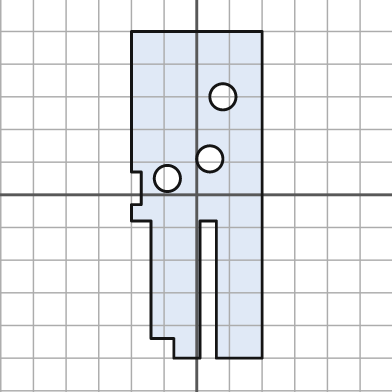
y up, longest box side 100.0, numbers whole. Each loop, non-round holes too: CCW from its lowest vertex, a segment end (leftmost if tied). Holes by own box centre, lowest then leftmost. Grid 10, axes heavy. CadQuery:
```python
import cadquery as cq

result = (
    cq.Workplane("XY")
    .moveTo(-7.0, -50.0)
    .lineTo(1.0, -50.0)
    .lineTo(1.0, -8.0)
    .lineTo(6.0, -8.0)
    .lineTo(6.0, -50.0)
    .lineTo(20.0, -50.0)
    .lineTo(20.0, 50.0)
    .lineTo(-20.0, 50.0)
    .lineTo(-20.0, 7.0)
    .lineTo(-17.0, 7.0)
    .lineTo(-17.0, -3.0)
    .lineTo(-20.0, -3.0)
    .lineTo(-20.0, -8.0)
    .lineTo(-14.0, -8.0)
    .lineTo(-14.0, -44.0)
    .lineTo(-7.0, -44.0)
    .close()
    .moveTo(-9.0, 5.0)
    .circle(4.0)
    .moveTo(4.0, 11.0)
    .circle(4.0)
    .moveTo(8.0, 30.0)
    .circle(4.0)
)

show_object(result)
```